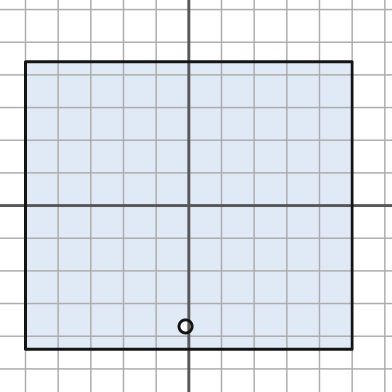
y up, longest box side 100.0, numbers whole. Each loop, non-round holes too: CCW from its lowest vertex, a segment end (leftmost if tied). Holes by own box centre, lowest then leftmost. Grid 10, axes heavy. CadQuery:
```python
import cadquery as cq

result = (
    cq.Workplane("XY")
    .moveTo(-50.0, -44.0)
    .lineTo(50.0, -44.0)
    .lineTo(50.0, 44.0)
    .lineTo(-50.0, 44.0)
    .close()
    .moveTo(-1.0, -37.0)
    .circle(2.0)
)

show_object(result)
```